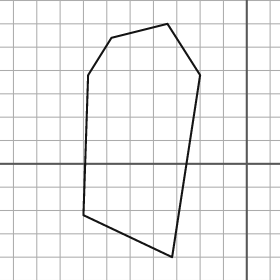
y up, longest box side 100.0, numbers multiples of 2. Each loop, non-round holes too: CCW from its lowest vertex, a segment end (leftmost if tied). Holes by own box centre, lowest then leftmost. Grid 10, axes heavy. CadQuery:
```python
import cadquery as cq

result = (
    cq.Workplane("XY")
    .moveTo(-32.0, -40.0)
    .lineTo(-20.0, 38.0)
    .lineTo(-34.0, 60.0)
    .lineTo(-58.0, 54.0)
    .lineTo(-68.0, 38.0)
    .lineTo(-70.0, -22.0)
    .close()
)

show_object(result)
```